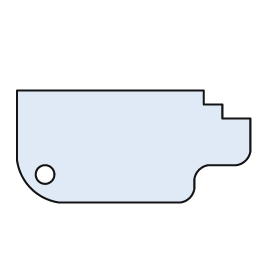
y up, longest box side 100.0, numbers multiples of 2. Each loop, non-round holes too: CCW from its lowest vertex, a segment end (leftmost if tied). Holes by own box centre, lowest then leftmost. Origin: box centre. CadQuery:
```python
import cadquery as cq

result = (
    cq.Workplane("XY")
    .moveTo(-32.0, -24.0)
    .lineTo(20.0, -24.0)
    .threePointArc((24.0, -22.0), (26.0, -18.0))
    .lineTo(26.0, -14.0)
    .threePointArc((28.0, -10.0), (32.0, -8.0))
    .lineTo(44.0, -8.0)
    .threePointArc((48.0, -6.0), (50.0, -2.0))
    .lineTo(50.0, 12.0)
    .lineTo(38.0, 12.0)
    .lineTo(38.0, 18.0)
    .lineTo(30.0, 18.0)
    .lineTo(30.0, 24.0)
    .lineTo(-50.0, 24.0)
    .lineTo(-50.0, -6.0)
    .threePointArc((-44.0, -18.0), (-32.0, -24.0))
    .close()
    .moveTo(-38.0, -12.0)
    .circle(4.0)
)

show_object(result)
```